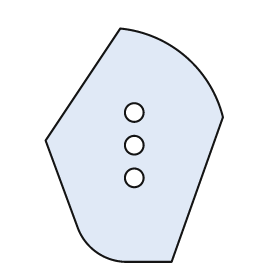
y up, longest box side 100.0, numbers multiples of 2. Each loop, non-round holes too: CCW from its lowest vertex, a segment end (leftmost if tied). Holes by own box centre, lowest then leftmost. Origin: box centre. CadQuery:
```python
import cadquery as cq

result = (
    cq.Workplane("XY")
    .moveTo(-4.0, -50.0)
    .lineTo(16.0, -50.0)
    .lineTo(38.0, 12.0)
    .threePointArc((22.0, 38.0), (-6.0, 50.0))
    .lineTo(-38.0, 2.0)
    .lineTo(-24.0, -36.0)
    .threePointArc((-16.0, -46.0), (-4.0, -50.0))
    .close()
    .moveTo(0.0, -14.0)
    .circle(4.0)
    .moveTo(0.0, 0.0)
    .circle(4.0)
    .moveTo(0.0, 14.0)
    .circle(4.0)
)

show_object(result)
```